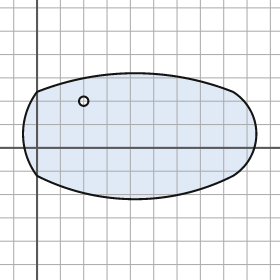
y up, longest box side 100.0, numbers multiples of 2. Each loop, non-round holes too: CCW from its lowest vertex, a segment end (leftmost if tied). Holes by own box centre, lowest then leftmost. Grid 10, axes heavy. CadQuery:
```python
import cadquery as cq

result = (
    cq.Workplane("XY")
    .moveTo(0.0, -12.0)
    .threePointArc((42.0, -22.0), (84.0, -12.0))
    .threePointArc((94.0, 6.0), (84.0, 24.0))
    .threePointArc((42.0, 32.0), (0.0, 24.0))
    .threePointArc((-6.0, 6.0), (0.0, -12.0))
    .close()
    .moveTo(20.0, 20.0)
    .circle(2.0)
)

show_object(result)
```